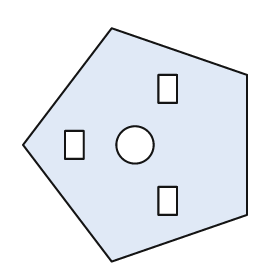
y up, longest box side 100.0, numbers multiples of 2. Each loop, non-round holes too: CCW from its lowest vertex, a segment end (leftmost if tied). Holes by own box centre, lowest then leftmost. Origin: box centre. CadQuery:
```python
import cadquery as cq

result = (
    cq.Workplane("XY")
    .moveTo(-10.0, -50.0)
    .lineTo(48.0, -30.0)
    .lineTo(48.0, 30.0)
    .lineTo(-10.0, 50.0)
    .lineTo(-48.0, 0.0)
    .close()
    .moveTo(10.0, -30.0)
    .lineTo(18.0, -30.0)
    .lineTo(18.0, -18.0)
    .lineTo(10.0, -18.0)
    .close()
    .moveTo(-30.0, -6.0)
    .lineTo(-22.0, -6.0)
    .lineTo(-22.0, 6.0)
    .lineTo(-30.0, 6.0)
    .close()
    .moveTo(0.0, 0.0)
    .circle(8.0)
    .moveTo(10.0, 18.0)
    .lineTo(18.0, 18.0)
    .lineTo(18.0, 30.0)
    .lineTo(10.0, 30.0)
    .close()
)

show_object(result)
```